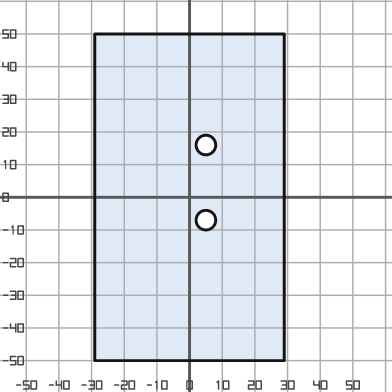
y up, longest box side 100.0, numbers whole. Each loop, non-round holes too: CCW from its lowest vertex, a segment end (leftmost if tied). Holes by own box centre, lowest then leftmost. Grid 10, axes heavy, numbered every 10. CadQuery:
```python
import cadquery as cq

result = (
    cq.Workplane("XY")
    .moveTo(-29.0, -50.0)
    .lineTo(29.0, -50.0)
    .lineTo(29.0, 50.0)
    .lineTo(-29.0, 50.0)
    .close()
    .moveTo(5.0, -7.0)
    .circle(3.0)
    .moveTo(5.0, 16.0)
    .circle(3.0)
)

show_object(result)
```